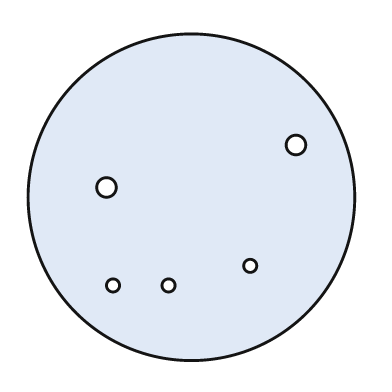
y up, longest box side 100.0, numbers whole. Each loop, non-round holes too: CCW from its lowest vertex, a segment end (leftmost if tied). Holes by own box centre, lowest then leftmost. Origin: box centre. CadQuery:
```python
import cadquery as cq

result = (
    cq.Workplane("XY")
    .moveTo(0.0, 0.0)
    .circle(50.0)
    .moveTo(-24.0, -27.0)
    .circle(2.0)
    .moveTo(-7.0, -27.0)
    .circle(2.0)
    .moveTo(18.0, -21.0)
    .circle(2.0)
    .moveTo(-26.0, 3.0)
    .circle(3.0)
    .moveTo(32.0, 16.0)
    .circle(3.0)
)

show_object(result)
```